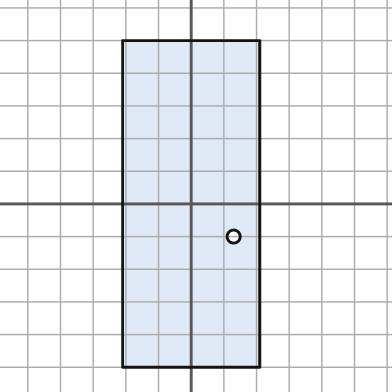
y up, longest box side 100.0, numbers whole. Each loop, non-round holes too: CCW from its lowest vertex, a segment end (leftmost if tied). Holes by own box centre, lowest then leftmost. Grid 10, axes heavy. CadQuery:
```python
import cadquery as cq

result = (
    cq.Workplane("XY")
    .moveTo(-21.0, -50.0)
    .lineTo(21.0, -50.0)
    .lineTo(21.0, 50.0)
    .lineTo(-21.0, 50.0)
    .close()
    .moveTo(13.0, -10.0)
    .circle(2.0)
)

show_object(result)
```